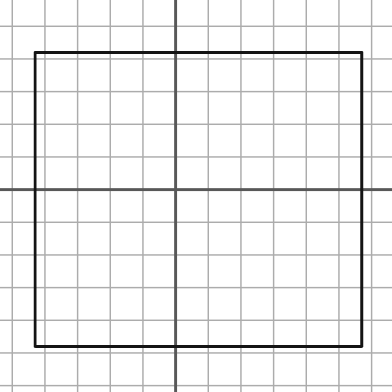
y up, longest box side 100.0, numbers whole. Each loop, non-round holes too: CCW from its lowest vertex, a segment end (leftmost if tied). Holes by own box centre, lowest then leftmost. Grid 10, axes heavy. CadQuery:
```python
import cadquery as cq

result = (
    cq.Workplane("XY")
    .moveTo(-43.0, -48.0)
    .lineTo(57.0, -48.0)
    .lineTo(57.0, 42.0)
    .lineTo(-43.0, 42.0)
    .close()
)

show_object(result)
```